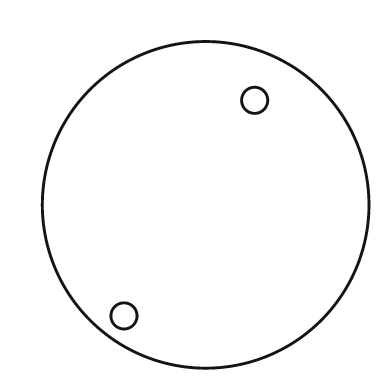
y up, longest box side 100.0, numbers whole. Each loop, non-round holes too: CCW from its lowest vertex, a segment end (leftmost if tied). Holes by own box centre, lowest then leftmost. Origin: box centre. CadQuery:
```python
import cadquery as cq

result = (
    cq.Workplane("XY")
    .moveTo(0.0, 0.0)
    .circle(50.0)
    .moveTo(-25.0, -34.0)
    .circle(4.0)
    .moveTo(15.0, 32.0)
    .circle(4.0)
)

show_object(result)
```